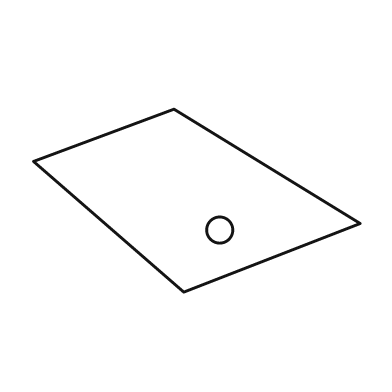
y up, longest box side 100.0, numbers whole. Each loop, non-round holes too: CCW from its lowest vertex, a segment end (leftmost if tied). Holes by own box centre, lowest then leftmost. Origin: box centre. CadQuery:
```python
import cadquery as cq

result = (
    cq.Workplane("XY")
    .moveTo(-4.0, -28.0)
    .lineTo(50.0, -7.0)
    .lineTo(-7.0, 28.0)
    .lineTo(-50.0, 12.0)
    .close()
    .moveTo(7.0, -9.0)
    .circle(4.0)
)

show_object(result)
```